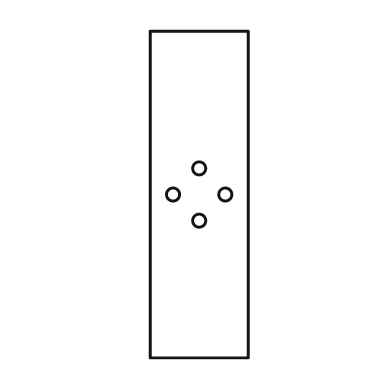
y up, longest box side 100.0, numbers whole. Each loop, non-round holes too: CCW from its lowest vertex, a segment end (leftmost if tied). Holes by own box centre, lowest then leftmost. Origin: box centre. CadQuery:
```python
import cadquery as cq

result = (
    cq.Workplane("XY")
    .moveTo(-15.0, -50.0)
    .lineTo(15.0, -50.0)
    .lineTo(15.0, 50.0)
    .lineTo(-15.0, 50.0)
    .close()
    .moveTo(0.0, -8.0)
    .circle(2.0)
    .moveTo(-8.0, 0.0)
    .circle(2.0)
    .moveTo(8.0, 0.0)
    .circle(2.0)
    .moveTo(0.0, 8.0)
    .circle(2.0)
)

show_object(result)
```